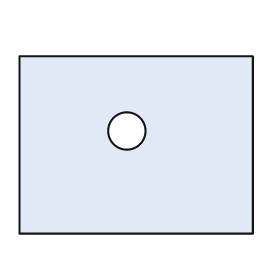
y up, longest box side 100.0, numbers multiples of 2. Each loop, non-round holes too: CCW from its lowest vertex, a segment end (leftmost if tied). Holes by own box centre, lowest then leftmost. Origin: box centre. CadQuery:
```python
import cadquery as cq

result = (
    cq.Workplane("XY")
    .moveTo(-50.0, -38.0)
    .lineTo(50.0, -38.0)
    .lineTo(50.0, 38.0)
    .lineTo(-50.0, 38.0)
    .close()
    .moveTo(-4.0, 6.0)
    .circle(8.0)
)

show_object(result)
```